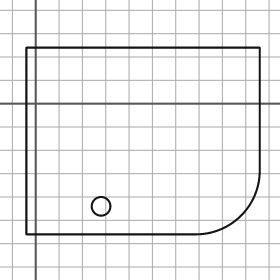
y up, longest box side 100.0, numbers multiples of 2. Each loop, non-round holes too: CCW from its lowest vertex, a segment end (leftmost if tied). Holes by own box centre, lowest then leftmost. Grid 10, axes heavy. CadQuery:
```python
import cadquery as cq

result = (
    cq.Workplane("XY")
    .moveTo(-4.0, -56.0)
    .lineTo(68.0, -56.0)
    .threePointArc((88.0, -48.0), (96.0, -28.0))
    .lineTo(96.0, 24.0)
    .lineTo(-4.0, 24.0)
    .close()
    .moveTo(28.0, -44.0)
    .circle(4.0)
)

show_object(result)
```